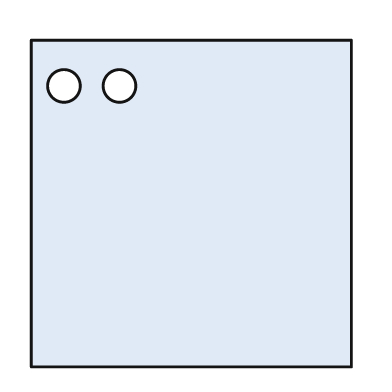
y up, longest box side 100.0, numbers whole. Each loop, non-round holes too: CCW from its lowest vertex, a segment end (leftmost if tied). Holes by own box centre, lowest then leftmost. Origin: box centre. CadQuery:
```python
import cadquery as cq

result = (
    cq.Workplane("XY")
    .moveTo(-49.0, -50.0)
    .lineTo(49.0, -50.0)
    .lineTo(49.0, 50.0)
    .lineTo(-49.0, 50.0)
    .close()
    .moveTo(-39.0, 36.0)
    .circle(5.0)
    .moveTo(-22.0, 36.0)
    .circle(5.0)
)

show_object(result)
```